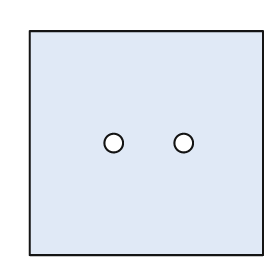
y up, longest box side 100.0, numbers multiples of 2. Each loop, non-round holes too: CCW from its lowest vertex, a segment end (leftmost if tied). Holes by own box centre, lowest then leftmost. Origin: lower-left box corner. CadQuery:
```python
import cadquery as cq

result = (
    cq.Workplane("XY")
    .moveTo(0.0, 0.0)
    .lineTo(100.0, 0.0)
    .lineTo(100.0, 96.0)
    .lineTo(0.0, 96.0)
    .close()
    .moveTo(36.0, 48.0)
    .circle(4.0)
    .moveTo(66.0, 48.0)
    .circle(4.0)
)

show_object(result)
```